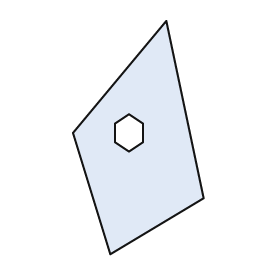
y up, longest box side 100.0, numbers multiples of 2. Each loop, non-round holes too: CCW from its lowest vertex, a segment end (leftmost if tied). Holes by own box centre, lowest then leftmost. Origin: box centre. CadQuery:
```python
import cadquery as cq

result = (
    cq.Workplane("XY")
    .moveTo(-12.0, -50.0)
    .lineTo(28.0, -26.0)
    .lineTo(12.0, 50.0)
    .lineTo(-28.0, 2.0)
    .close()
    .moveTo(-4.0, -6.0)
    .lineTo(2.0, -2.0)
    .lineTo(2.0, 6.0)
    .lineTo(-4.0, 10.0)
    .lineTo(-10.0, 6.0)
    .lineTo(-10.0, -2.0)
    .close()
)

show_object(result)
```